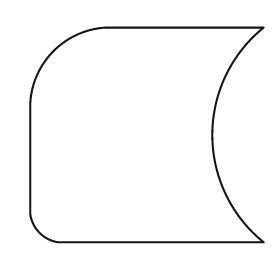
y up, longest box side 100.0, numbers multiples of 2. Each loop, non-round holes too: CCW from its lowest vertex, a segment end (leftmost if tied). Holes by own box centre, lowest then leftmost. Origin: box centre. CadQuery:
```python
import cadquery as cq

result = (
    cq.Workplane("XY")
    .moveTo(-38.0, -46.0)
    .lineTo(50.0, -46.0)
    .threePointArc((28.0, 0.0), (50.0, 46.0))
    .lineTo(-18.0, 46.0)
    .threePointArc((-40.0, 36.0), (-50.0, 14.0))
    .lineTo(-50.0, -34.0)
    .threePointArc((-46.0, -42.0), (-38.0, -46.0))
    .close()
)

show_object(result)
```